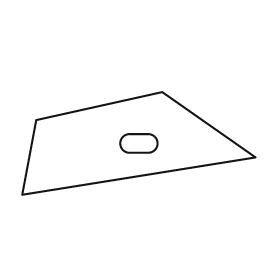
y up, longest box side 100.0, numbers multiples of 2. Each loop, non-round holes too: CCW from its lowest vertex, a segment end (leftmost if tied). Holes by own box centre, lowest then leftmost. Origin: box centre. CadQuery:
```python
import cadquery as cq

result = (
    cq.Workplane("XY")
    .moveTo(-50.0, -22.0)
    .lineTo(50.0, -6.0)
    .lineTo(10.0, 22.0)
    .lineTo(-44.0, 10.0)
    .close()
    .moveTo(-4.0, -4.0)
    .lineTo(4.0, -4.0)
    .threePointArc((8.0, 0.0), (4.0, 4.0))
    .lineTo(-4.0, 4.0)
    .threePointArc((-8.0, 0.0), (-4.0, -4.0))
    .close()
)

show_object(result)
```